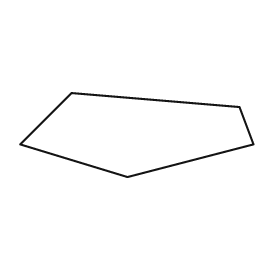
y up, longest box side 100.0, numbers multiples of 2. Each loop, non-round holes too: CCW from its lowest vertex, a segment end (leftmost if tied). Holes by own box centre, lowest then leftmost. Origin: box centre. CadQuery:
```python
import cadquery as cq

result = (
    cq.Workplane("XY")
    .moveTo(-4.0, -18.0)
    .lineTo(50.0, -4.0)
    .lineTo(44.0, 12.0)
    .lineTo(-28.0, 18.0)
    .lineTo(-50.0, -4.0)
    .close()
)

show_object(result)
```